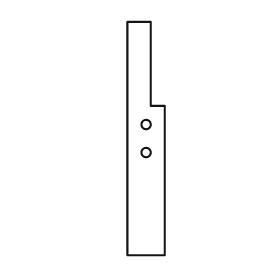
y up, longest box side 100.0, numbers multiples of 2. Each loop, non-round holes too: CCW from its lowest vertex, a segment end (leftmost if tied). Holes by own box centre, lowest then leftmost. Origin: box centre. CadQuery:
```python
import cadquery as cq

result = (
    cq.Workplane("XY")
    .moveTo(-8.0, -50.0)
    .lineTo(8.0, -50.0)
    .lineTo(8.0, 14.0)
    .lineTo(2.0, 14.0)
    .lineTo(2.0, 50.0)
    .lineTo(-8.0, 50.0)
    .close()
    .moveTo(0.0, -6.0)
    .circle(2.0)
    .moveTo(0.0, 6.0)
    .circle(2.0)
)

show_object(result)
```